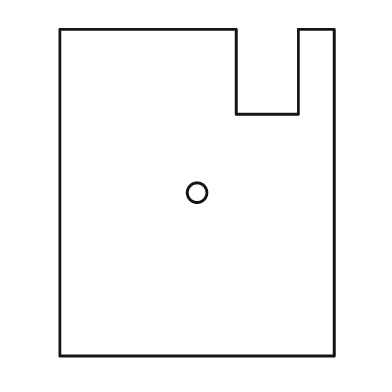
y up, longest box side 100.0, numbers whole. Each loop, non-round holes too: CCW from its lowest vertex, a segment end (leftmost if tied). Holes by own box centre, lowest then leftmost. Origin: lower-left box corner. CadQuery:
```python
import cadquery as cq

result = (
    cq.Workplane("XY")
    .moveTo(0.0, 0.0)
    .lineTo(84.0, 0.0)
    .lineTo(84.0, 100.0)
    .lineTo(73.0, 100.0)
    .lineTo(73.0, 74.0)
    .lineTo(54.0, 74.0)
    .lineTo(54.0, 100.0)
    .lineTo(0.0, 100.0)
    .close()
    .moveTo(42.0, 50.0)
    .circle(3.0)
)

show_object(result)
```